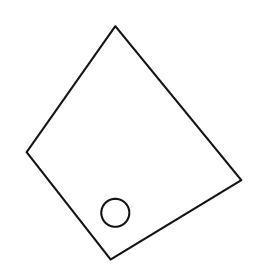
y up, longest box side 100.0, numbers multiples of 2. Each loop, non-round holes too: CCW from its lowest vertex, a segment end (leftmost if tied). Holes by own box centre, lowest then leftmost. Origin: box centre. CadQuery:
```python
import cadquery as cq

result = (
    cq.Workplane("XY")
    .moveTo(-10.0, -50.0)
    .lineTo(46.0, -16.0)
    .lineTo(-8.0, 50.0)
    .lineTo(-46.0, -4.0)
    .close()
    .moveTo(-8.0, -30.0)
    .circle(6.0)
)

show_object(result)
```